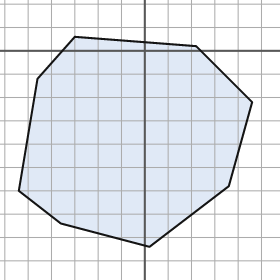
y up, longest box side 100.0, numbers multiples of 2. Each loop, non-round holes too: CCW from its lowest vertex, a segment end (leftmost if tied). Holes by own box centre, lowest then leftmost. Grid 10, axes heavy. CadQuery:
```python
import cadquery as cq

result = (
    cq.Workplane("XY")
    .moveTo(2.0, -84.0)
    .lineTo(36.0, -58.0)
    .lineTo(46.0, -22.0)
    .lineTo(22.0, 2.0)
    .lineTo(-30.0, 6.0)
    .lineTo(-46.0, -12.0)
    .lineTo(-54.0, -60.0)
    .lineTo(-36.0, -74.0)
    .close()
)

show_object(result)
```